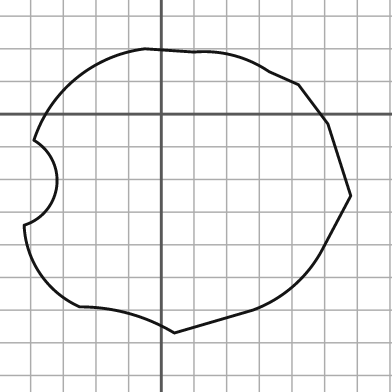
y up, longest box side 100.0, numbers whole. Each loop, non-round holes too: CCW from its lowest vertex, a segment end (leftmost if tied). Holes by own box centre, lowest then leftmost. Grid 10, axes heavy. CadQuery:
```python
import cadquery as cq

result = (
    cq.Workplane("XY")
    .moveTo(4.0, -67.0)
    .lineTo(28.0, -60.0)
    .threePointArc((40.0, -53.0), (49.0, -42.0))
    .lineTo(58.0, -25.0)
    .lineTo(51.0, -3.0)
    .lineTo(42.0, 9.0)
    .lineTo(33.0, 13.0)
    .threePointArc((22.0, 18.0), (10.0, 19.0))
    .lineTo(-5.0, 20.0)
    .threePointArc((-26.0, 11.0), (-39.0, -8.0))
    .threePointArc((-32.0, -22.0), (-42.0, -34.0))
    .threePointArc((-37.0, -49.0), (-25.0, -59.0))
    .threePointArc((-10.0, -61.0), (4.0, -67.0))
    .close()
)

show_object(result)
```